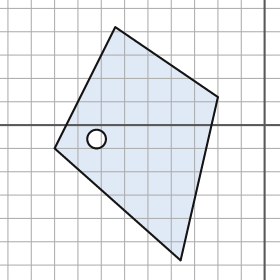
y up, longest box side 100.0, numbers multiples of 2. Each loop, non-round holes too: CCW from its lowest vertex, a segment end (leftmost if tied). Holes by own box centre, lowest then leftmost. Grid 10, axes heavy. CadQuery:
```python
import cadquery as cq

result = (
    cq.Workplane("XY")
    .moveTo(-36.0, -58.0)
    .lineTo(-20.0, 12.0)
    .lineTo(-64.0, 42.0)
    .lineTo(-90.0, -10.0)
    .close()
    .moveTo(-72.0, -6.0)
    .circle(4.0)
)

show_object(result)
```